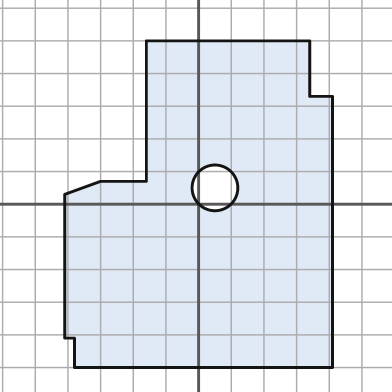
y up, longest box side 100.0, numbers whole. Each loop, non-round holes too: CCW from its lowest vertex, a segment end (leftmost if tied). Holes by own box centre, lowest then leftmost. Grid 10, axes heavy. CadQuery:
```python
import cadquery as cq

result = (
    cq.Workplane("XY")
    .moveTo(-38.0, -50.0)
    .lineTo(41.0, -50.0)
    .lineTo(41.0, 33.0)
    .lineTo(34.0, 33.0)
    .lineTo(34.0, 50.0)
    .lineTo(-16.0, 50.0)
    .lineTo(-16.0, 7.0)
    .lineTo(-30.0, 7.0)
    .lineTo(-41.0, 3.0)
    .lineTo(-41.0, -41.0)
    .lineTo(-38.0, -41.0)
    .close()
    .moveTo(5.0, 5.0)
    .circle(7.0)
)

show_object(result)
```